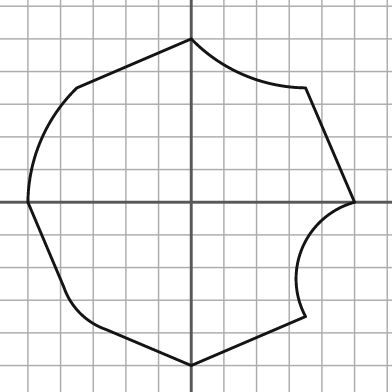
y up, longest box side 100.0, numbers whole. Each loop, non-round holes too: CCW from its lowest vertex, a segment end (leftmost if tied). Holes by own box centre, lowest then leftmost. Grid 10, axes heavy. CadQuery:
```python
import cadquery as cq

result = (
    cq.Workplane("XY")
    .moveTo(0.0, -50.0)
    .lineTo(35.0, -35.0)
    .threePointArc((34.0, -14.0), (50.0, 0.0))
    .lineTo(35.0, 35.0)
    .threePointArc((16.0, 39.0), (0.0, 50.0))
    .lineTo(-35.0, 35.0)
    .threePointArc((-46.0, 19.0), (-50.0, 0.0))
    .lineTo(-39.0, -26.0)
    .threePointArc((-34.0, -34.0), (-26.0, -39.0))
    .close()
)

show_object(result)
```